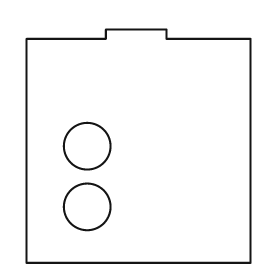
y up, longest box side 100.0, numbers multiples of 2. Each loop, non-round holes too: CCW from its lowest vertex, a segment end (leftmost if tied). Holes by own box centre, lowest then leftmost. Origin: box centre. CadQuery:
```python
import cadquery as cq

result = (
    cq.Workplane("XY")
    .moveTo(-48.0, -50.0)
    .lineTo(48.0, -50.0)
    .lineTo(48.0, 46.0)
    .lineTo(12.0, 46.0)
    .lineTo(12.0, 50.0)
    .lineTo(-14.0, 50.0)
    .lineTo(-14.0, 46.0)
    .lineTo(-48.0, 46.0)
    .close()
    .moveTo(-22.0, -26.0)
    .circle(10.0)
    .moveTo(-22.0, 0.0)
    .circle(10.0)
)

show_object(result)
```